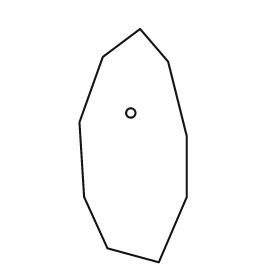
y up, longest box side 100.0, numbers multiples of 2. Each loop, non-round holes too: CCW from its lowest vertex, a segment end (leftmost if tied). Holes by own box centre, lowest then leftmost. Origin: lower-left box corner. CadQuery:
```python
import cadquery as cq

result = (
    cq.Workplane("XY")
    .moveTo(34.0, 0.0)
    .lineTo(46.0, 28.0)
    .lineTo(46.0, 54.0)
    .lineTo(38.0, 86.0)
    .lineTo(26.0, 100.0)
    .lineTo(10.0, 88.0)
    .lineTo(0.0, 60.0)
    .lineTo(2.0, 28.0)
    .lineTo(12.0, 6.0)
    .close()
    .moveTo(22.0, 64.0)
    .circle(2.0)
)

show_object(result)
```